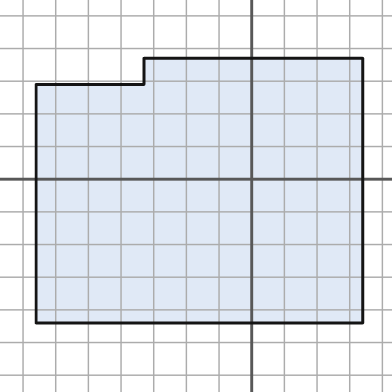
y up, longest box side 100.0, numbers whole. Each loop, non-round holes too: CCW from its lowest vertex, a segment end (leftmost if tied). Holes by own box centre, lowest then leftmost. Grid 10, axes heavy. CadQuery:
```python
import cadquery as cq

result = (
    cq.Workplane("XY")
    .moveTo(-66.0, -44.0)
    .lineTo(34.0, -44.0)
    .lineTo(34.0, 37.0)
    .lineTo(-33.0, 37.0)
    .lineTo(-33.0, 29.0)
    .lineTo(-66.0, 29.0)
    .close()
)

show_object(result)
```